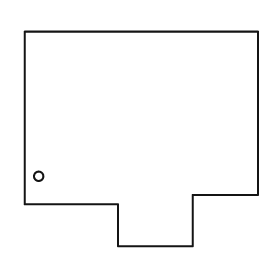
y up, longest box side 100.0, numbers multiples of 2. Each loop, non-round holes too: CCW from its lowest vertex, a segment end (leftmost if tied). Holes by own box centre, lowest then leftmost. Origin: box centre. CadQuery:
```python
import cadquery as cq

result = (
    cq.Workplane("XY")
    .moveTo(-10.0, -46.0)
    .lineTo(22.0, -46.0)
    .lineTo(22.0, -24.0)
    .lineTo(50.0, -24.0)
    .lineTo(50.0, 46.0)
    .lineTo(-50.0, 46.0)
    .lineTo(-50.0, -28.0)
    .lineTo(-10.0, -28.0)
    .close()
    .moveTo(-44.0, -16.0)
    .circle(2.0)
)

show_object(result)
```